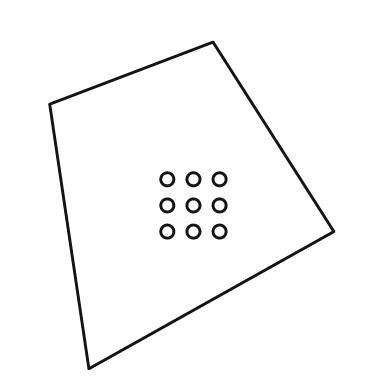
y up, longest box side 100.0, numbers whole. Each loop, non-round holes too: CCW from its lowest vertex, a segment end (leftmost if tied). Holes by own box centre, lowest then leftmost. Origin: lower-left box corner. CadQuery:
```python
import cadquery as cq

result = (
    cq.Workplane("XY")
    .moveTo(12.0, 0.0)
    .lineTo(87.0, 42.0)
    .lineTo(50.0, 100.0)
    .lineTo(0.0, 81.0)
    .close()
    .moveTo(36.0, 42.0)
    .circle(2.0)
    .moveTo(44.0, 42.0)
    .circle(2.0)
    .moveTo(52.0, 42.0)
    .circle(2.0)
    .moveTo(36.0, 50.0)
    .circle(2.0)
    .moveTo(44.0, 50.0)
    .circle(2.0)
    .moveTo(52.0, 50.0)
    .circle(2.0)
    .moveTo(36.0, 58.0)
    .circle(2.0)
    .moveTo(44.0, 58.0)
    .circle(2.0)
    .moveTo(52.0, 58.0)
    .circle(2.0)
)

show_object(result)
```